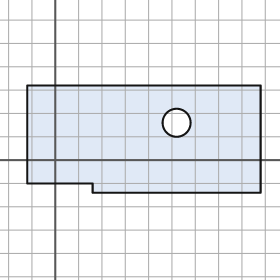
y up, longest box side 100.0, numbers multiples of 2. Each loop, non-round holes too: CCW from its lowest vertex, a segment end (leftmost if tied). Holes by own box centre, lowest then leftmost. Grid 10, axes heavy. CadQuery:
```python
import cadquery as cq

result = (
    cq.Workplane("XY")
    .moveTo(16.0, -14.0)
    .lineTo(88.0, -14.0)
    .lineTo(88.0, 32.0)
    .lineTo(-12.0, 32.0)
    .lineTo(-12.0, -10.0)
    .lineTo(16.0, -10.0)
    .close()
    .moveTo(52.0, 16.0)
    .circle(6.0)
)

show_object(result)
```